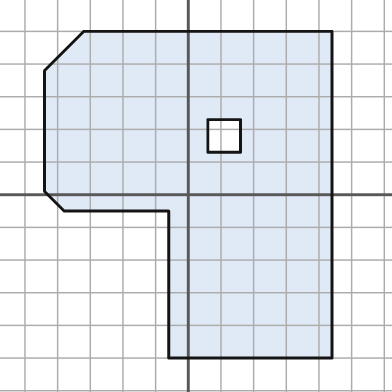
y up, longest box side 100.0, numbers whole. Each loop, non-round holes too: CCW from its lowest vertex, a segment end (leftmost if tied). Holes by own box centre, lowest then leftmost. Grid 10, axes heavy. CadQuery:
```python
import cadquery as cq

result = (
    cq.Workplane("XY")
    .moveTo(-6.0, -50.0)
    .lineTo(44.0, -50.0)
    .lineTo(44.0, 50.0)
    .lineTo(-32.0, 50.0)
    .lineTo(-44.0, 38.0)
    .lineTo(-44.0, 1.0)
    .lineTo(-38.0, -5.0)
    .lineTo(-6.0, -5.0)
    .close()
    .moveTo(6.0, 13.0)
    .lineTo(16.0, 13.0)
    .lineTo(16.0, 23.0)
    .lineTo(6.0, 23.0)
    .close()
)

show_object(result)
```